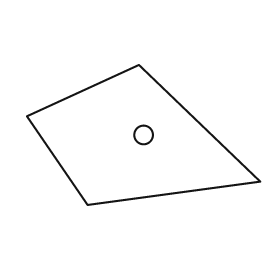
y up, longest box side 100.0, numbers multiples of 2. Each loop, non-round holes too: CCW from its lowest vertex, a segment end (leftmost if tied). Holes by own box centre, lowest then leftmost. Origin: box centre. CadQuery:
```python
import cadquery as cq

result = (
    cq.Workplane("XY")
    .moveTo(-24.0, -30.0)
    .lineTo(50.0, -20.0)
    .lineTo(-2.0, 30.0)
    .lineTo(-50.0, 8.0)
    .close()
    .moveTo(0.0, 0.0)
    .circle(4.0)
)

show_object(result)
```